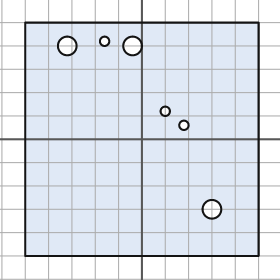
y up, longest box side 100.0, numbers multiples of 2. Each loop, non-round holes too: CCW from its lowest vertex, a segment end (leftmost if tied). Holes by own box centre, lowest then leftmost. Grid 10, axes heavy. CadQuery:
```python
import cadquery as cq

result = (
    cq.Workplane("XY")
    .moveTo(-50.0, -50.0)
    .lineTo(50.0, -50.0)
    .lineTo(50.0, 50.0)
    .lineTo(-50.0, 50.0)
    .close()
    .moveTo(30.0, -30.0)
    .circle(4.0)
    .moveTo(18.0, 6.0)
    .circle(2.0)
    .moveTo(10.0, 12.0)
    .circle(2.0)
    .moveTo(-32.0, 40.0)
    .circle(4.0)
    .moveTo(-4.0, 40.0)
    .circle(4.0)
    .moveTo(-16.0, 42.0)
    .circle(2.0)
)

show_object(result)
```